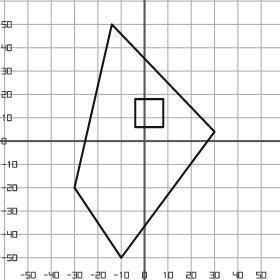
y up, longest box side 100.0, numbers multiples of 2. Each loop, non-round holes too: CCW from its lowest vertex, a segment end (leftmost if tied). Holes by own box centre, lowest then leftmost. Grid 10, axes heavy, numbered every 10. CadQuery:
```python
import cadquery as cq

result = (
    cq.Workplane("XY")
    .moveTo(-10.0, -50.0)
    .lineTo(30.0, 4.0)
    .lineTo(-14.0, 50.0)
    .lineTo(-30.0, -20.0)
    .close()
    .moveTo(-4.0, 6.0)
    .lineTo(8.0, 6.0)
    .lineTo(8.0, 18.0)
    .lineTo(-4.0, 18.0)
    .close()
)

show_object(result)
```